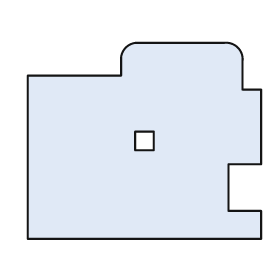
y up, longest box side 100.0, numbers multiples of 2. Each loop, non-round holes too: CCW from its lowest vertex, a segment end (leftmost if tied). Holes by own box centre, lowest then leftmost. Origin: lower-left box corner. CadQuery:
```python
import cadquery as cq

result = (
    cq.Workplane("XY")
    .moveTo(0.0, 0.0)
    .lineTo(100.0, 0.0)
    .lineTo(100.0, 12.0)
    .lineTo(86.0, 12.0)
    .lineTo(86.0, 32.0)
    .lineTo(100.0, 32.0)
    .lineTo(100.0, 64.0)
    .lineTo(92.0, 64.0)
    .lineTo(92.0, 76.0)
    .threePointArc((90.0, 82.0), (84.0, 84.0))
    .lineTo(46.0, 84.0)
    .threePointArc((42.0, 82.0), (40.0, 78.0))
    .lineTo(40.0, 70.0)
    .lineTo(0.0, 70.0)
    .close()
    .moveTo(46.0, 38.0)
    .lineTo(54.0, 38.0)
    .lineTo(54.0, 46.0)
    .lineTo(46.0, 46.0)
    .close()
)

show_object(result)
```